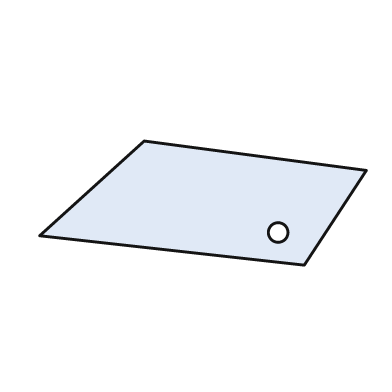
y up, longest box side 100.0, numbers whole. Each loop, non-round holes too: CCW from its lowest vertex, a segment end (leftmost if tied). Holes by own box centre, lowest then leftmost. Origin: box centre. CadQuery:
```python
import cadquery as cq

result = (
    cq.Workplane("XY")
    .moveTo(31.0, -19.0)
    .lineTo(50.0, 10.0)
    .lineTo(-18.0, 19.0)
    .lineTo(-50.0, -10.0)
    .close()
    .moveTo(23.0, -9.0)
    .circle(3.0)
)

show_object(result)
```